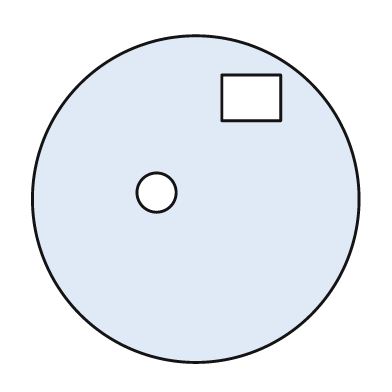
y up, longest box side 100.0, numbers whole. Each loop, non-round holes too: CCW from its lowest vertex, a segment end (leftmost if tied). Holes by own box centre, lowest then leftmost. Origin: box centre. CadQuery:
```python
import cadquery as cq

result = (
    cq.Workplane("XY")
    .moveTo(0.0, 0.0)
    .circle(50.0)
    .moveTo(-12.0, 2.0)
    .circle(6.0)
    .moveTo(8.0, 24.0)
    .lineTo(26.0, 24.0)
    .lineTo(26.0, 38.0)
    .lineTo(8.0, 38.0)
    .close()
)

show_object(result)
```